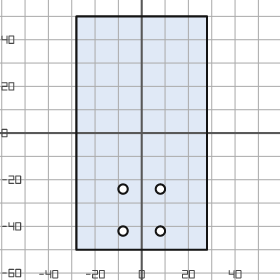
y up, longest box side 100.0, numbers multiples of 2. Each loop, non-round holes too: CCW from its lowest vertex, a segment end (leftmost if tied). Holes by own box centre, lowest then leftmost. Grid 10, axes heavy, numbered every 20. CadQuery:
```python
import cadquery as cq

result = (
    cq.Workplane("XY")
    .moveTo(-28.0, -50.0)
    .lineTo(28.0, -50.0)
    .lineTo(28.0, 50.0)
    .lineTo(-28.0, 50.0)
    .close()
    .moveTo(-8.0, -42.0)
    .circle(2.0)
    .moveTo(8.0, -42.0)
    .circle(2.0)
    .moveTo(-8.0, -24.0)
    .circle(2.0)
    .moveTo(8.0, -24.0)
    .circle(2.0)
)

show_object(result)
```